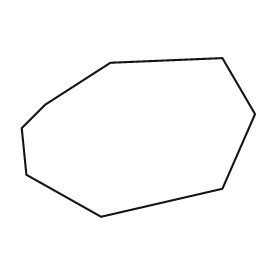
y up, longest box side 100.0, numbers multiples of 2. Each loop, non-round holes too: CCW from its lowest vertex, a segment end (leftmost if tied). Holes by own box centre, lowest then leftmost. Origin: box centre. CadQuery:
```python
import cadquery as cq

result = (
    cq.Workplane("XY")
    .moveTo(-16.0, -34.0)
    .lineTo(36.0, -22.0)
    .lineTo(50.0, 10.0)
    .lineTo(36.0, 34.0)
    .lineTo(-12.0, 32.0)
    .lineTo(-40.0, 14.0)
    .lineTo(-50.0, 4.0)
    .lineTo(-48.0, -16.0)
    .close()
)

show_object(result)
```